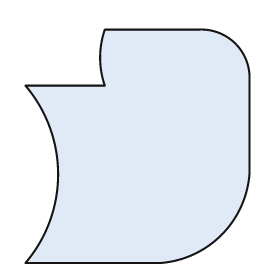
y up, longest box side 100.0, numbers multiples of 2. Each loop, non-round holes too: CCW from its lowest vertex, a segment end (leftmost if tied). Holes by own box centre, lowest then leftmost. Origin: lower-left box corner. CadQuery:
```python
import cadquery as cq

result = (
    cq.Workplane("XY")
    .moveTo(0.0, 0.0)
    .lineTo(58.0, 0.0)
    .threePointArc((84.0, 12.0), (96.0, 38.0))
    .lineTo(96.0, 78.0)
    .threePointArc((90.0, 94.0), (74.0, 100.0))
    .lineTo(34.0, 100.0)
    .threePointArc((32.0, 88.0), (34.0, 76.0))
    .lineTo(0.0, 76.0)
    .threePointArc((14.0, 38.0), (0.0, 0.0))
    .close()
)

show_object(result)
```